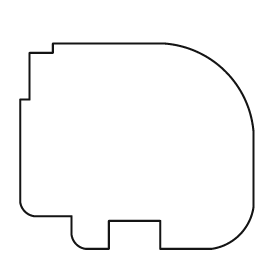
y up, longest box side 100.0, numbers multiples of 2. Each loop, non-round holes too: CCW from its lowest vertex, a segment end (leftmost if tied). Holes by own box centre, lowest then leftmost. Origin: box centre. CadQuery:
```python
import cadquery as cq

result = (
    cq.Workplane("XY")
    .moveTo(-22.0, -44.0)
    .lineTo(-12.0, -44.0)
    .lineTo(-12.0, -32.0)
    .lineTo(10.0, -32.0)
    .lineTo(10.0, -44.0)
    .lineTo(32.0, -44.0)
    .threePointArc((44.0, -38.0), (50.0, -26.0))
    .lineTo(50.0, 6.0)
    .threePointArc((38.0, 32.0), (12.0, 44.0))
    .lineTo(-36.0, 44.0)
    .lineTo(-36.0, 40.0)
    .lineTo(-46.0, 40.0)
    .lineTo(-46.0, 20.0)
    .lineTo(-50.0, 20.0)
    .lineTo(-50.0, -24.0)
    .threePointArc((-48.0, -28.0), (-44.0, -30.0))
    .lineTo(-28.0, -30.0)
    .lineTo(-28.0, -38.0)
    .threePointArc((-26.0, -42.0), (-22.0, -44.0))
    .close()
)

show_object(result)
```